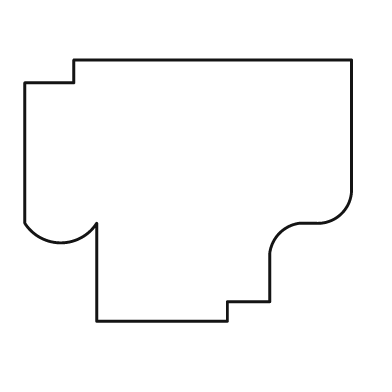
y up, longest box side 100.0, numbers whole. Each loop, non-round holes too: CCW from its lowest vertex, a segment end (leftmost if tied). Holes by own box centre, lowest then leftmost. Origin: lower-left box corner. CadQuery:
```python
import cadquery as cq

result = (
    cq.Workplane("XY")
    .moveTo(22.0, 0.0)
    .lineTo(62.0, 0.0)
    .lineTo(62.0, 6.0)
    .lineTo(75.0, 6.0)
    .lineTo(75.0, 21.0)
    .threePointArc((78.0, 27.0), (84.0, 30.0))
    .lineTo(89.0, 30.0)
    .threePointArc((97.0, 33.0), (100.0, 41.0))
    .lineTo(100.0, 80.0)
    .lineTo(15.0, 80.0)
    .lineTo(15.0, 73.0)
    .lineTo(0.0, 73.0)
    .lineTo(0.0, 30.0)
    .threePointArc((11.0, 24.0), (22.0, 30.0))
    .close()
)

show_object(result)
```